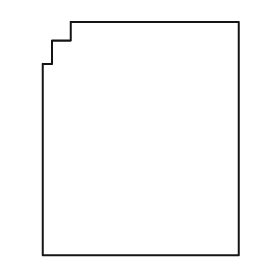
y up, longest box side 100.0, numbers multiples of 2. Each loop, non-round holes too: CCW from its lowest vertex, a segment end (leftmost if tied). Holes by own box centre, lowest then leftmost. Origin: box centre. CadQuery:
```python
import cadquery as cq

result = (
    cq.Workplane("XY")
    .moveTo(-42.0, -50.0)
    .lineTo(42.0, -50.0)
    .lineTo(42.0, 50.0)
    .lineTo(-30.0, 50.0)
    .lineTo(-30.0, 42.0)
    .lineTo(-38.0, 42.0)
    .lineTo(-38.0, 32.0)
    .lineTo(-42.0, 32.0)
    .close()
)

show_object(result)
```